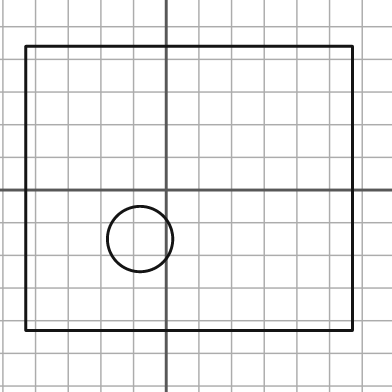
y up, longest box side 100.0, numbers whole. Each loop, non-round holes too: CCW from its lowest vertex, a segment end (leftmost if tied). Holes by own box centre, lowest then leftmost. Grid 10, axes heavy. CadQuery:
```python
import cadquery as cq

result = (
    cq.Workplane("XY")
    .moveTo(-43.0, -43.0)
    .lineTo(57.0, -43.0)
    .lineTo(57.0, 44.0)
    .lineTo(-43.0, 44.0)
    .close()
    .moveTo(-8.0, -15.0)
    .circle(10.0)
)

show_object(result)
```